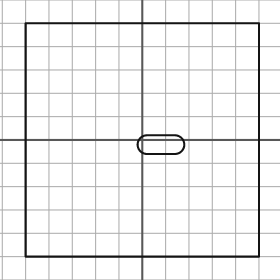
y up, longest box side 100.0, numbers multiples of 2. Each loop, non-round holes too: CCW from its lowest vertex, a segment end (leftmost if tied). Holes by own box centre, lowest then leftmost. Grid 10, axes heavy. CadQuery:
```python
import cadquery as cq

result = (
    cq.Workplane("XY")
    .moveTo(-50.0, -50.0)
    .lineTo(50.0, -50.0)
    .lineTo(50.0, 50.0)
    .lineTo(-50.0, 50.0)
    .close()
    .moveTo(2.0, -6.0)
    .lineTo(14.0, -6.0)
    .threePointArc((18.0, -2.0), (14.0, 2.0))
    .lineTo(2.0, 2.0)
    .threePointArc((-2.0, -2.0), (2.0, -6.0))
    .close()
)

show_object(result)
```